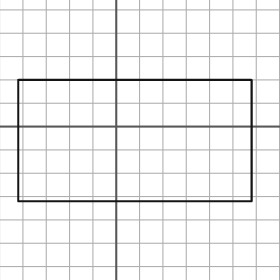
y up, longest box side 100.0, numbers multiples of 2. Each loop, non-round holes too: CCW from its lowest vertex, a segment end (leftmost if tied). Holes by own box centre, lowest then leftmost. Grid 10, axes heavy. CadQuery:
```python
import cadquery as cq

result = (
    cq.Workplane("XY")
    .moveTo(-42.0, -32.0)
    .lineTo(58.0, -32.0)
    .lineTo(58.0, 20.0)
    .lineTo(-42.0, 20.0)
    .close()
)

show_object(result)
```